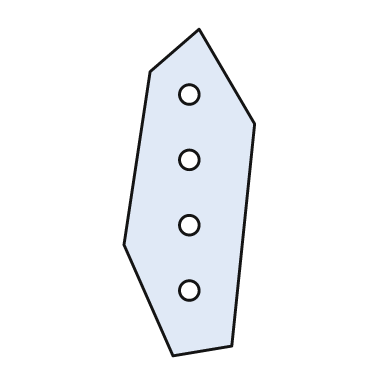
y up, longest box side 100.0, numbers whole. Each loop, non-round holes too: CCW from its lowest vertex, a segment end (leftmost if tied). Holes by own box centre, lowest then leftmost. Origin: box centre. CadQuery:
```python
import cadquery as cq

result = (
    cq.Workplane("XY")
    .moveTo(-5.0, -50.0)
    .lineTo(13.0, -47.0)
    .lineTo(20.0, 21.0)
    .lineTo(3.0, 50.0)
    .lineTo(-12.0, 37.0)
    .lineTo(-20.0, -16.0)
    .close()
    .moveTo(0.0, -30.0)
    .circle(3.0)
    .moveTo(0.0, -10.0)
    .circle(3.0)
    .moveTo(0.0, 10.0)
    .circle(3.0)
    .moveTo(0.0, 30.0)
    .circle(3.0)
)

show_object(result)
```